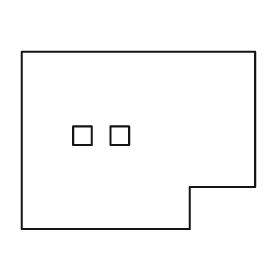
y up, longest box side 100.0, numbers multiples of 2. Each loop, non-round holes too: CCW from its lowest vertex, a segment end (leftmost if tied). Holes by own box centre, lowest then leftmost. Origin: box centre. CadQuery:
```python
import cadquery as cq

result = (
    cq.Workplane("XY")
    .moveTo(-50.0, -38.0)
    .lineTo(22.0, -38.0)
    .lineTo(22.0, -20.0)
    .lineTo(50.0, -20.0)
    .lineTo(50.0, 38.0)
    .lineTo(-50.0, 38.0)
    .close()
    .moveTo(-28.0, -2.0)
    .lineTo(-20.0, -2.0)
    .lineTo(-20.0, 6.0)
    .lineTo(-28.0, 6.0)
    .close()
    .moveTo(-12.0, -2.0)
    .lineTo(-4.0, -2.0)
    .lineTo(-4.0, 6.0)
    .lineTo(-12.0, 6.0)
    .close()
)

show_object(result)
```